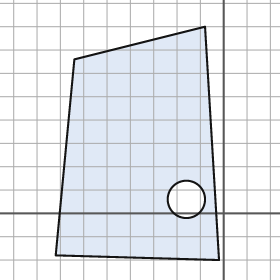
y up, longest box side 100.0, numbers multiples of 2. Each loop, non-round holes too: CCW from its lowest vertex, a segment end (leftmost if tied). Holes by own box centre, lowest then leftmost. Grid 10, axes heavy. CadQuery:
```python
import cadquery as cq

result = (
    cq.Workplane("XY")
    .moveTo(-2.0, -20.0)
    .lineTo(-8.0, 80.0)
    .lineTo(-64.0, 66.0)
    .lineTo(-72.0, -18.0)
    .close()
    .moveTo(-16.0, 6.0)
    .circle(8.0)
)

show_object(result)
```